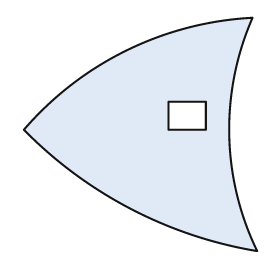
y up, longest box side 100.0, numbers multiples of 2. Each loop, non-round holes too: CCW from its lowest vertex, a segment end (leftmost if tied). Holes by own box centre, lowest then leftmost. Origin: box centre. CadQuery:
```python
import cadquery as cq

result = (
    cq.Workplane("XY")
    .moveTo(50.0, -50.0)
    .threePointArc((38.0, 0.0), (48.0, 50.0))
    .threePointArc((-6.0, 36.0), (-50.0, 2.0))
    .threePointArc((-4.0, -32.0), (50.0, -50.0))
    .close()
    .moveTo(12.0, 2.0)
    .lineTo(28.0, 2.0)
    .lineTo(28.0, 14.0)
    .lineTo(12.0, 14.0)
    .close()
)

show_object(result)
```